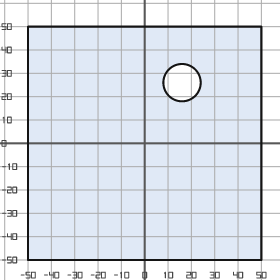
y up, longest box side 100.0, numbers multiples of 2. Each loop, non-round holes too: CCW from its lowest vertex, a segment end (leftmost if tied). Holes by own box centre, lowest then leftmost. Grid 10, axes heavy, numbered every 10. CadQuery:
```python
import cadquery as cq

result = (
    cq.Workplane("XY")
    .moveTo(-50.0, -50.0)
    .lineTo(50.0, -50.0)
    .lineTo(50.0, 50.0)
    .lineTo(-50.0, 50.0)
    .close()
    .moveTo(16.0, 26.0)
    .circle(8.0)
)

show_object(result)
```